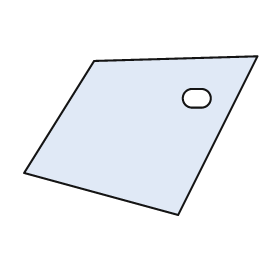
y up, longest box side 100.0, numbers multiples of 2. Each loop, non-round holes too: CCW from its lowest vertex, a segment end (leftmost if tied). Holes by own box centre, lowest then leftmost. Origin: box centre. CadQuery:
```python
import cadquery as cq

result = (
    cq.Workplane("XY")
    .moveTo(16.0, -34.0)
    .lineTo(50.0, 34.0)
    .lineTo(-20.0, 32.0)
    .lineTo(-50.0, -16.0)
    .close()
    .moveTo(22.0, 12.0)
    .lineTo(26.0, 12.0)
    .threePointArc((30.0, 16.0), (26.0, 20.0))
    .lineTo(22.0, 20.0)
    .threePointArc((18.0, 16.0), (22.0, 12.0))
    .close()
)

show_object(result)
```